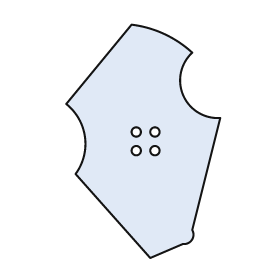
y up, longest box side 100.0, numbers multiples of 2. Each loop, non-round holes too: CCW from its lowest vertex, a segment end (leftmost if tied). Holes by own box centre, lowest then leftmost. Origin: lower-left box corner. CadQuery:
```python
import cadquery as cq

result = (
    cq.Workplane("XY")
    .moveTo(36.0, 0.0)
    .lineTo(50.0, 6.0)
    .threePointArc((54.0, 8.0), (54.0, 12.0))
    .lineTo(66.0, 60.0)
    .threePointArc((50.0, 70.0), (54.0, 88.0))
    .threePointArc((42.0, 96.0), (28.0, 100.0))
    .lineTo(0.0, 66.0)
    .threePointArc((8.0, 52.0), (4.0, 36.0))
    .close()
    .moveTo(30.0, 46.0)
    .circle(2.0)
    .moveTo(38.0, 46.0)
    .circle(2.0)
    .moveTo(30.0, 54.0)
    .circle(2.0)
    .moveTo(38.0, 54.0)
    .circle(2.0)
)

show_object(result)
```